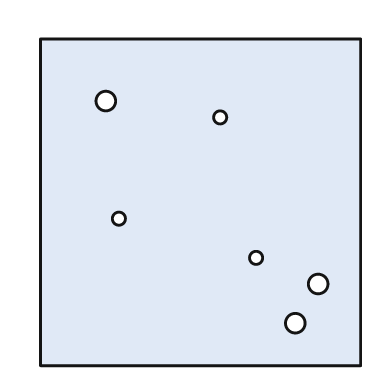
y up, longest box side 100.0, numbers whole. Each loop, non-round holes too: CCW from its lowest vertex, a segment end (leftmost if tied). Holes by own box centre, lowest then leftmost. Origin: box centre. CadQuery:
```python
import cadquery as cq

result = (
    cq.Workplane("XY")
    .moveTo(-49.0, -50.0)
    .lineTo(49.0, -50.0)
    .lineTo(49.0, 50.0)
    .lineTo(-49.0, 50.0)
    .close()
    .moveTo(29.0, -37.0)
    .circle(3.0)
    .moveTo(36.0, -25.0)
    .circle(3.0)
    .moveTo(17.0, -17.0)
    .circle(2.0)
    .moveTo(-25.0, -5.0)
    .circle(2.0)
    .moveTo(6.0, 26.0)
    .circle(2.0)
    .moveTo(-29.0, 31.0)
    .circle(3.0)
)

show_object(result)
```